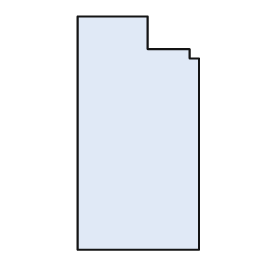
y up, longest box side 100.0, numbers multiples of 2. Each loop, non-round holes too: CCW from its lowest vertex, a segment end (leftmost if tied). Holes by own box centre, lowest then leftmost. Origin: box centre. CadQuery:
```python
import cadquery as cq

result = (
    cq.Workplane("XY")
    .moveTo(-26.0, -50.0)
    .lineTo(26.0, -50.0)
    .lineTo(26.0, 32.0)
    .lineTo(22.0, 32.0)
    .lineTo(22.0, 36.0)
    .lineTo(4.0, 36.0)
    .lineTo(4.0, 50.0)
    .lineTo(-26.0, 50.0)
    .close()
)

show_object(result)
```